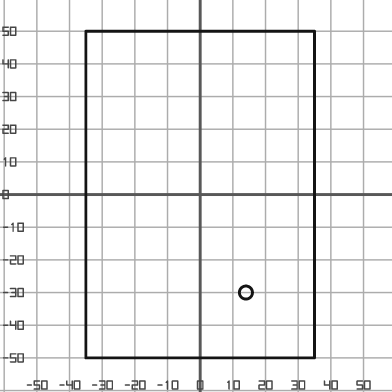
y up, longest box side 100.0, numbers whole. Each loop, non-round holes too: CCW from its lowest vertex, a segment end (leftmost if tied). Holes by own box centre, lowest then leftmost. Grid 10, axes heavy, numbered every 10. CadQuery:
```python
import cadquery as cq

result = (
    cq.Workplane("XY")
    .moveTo(-35.0, -50.0)
    .lineTo(35.0, -50.0)
    .lineTo(35.0, 50.0)
    .lineTo(-35.0, 50.0)
    .close()
    .moveTo(14.0, -30.0)
    .circle(2.0)
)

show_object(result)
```